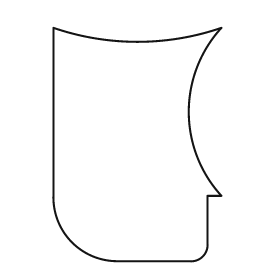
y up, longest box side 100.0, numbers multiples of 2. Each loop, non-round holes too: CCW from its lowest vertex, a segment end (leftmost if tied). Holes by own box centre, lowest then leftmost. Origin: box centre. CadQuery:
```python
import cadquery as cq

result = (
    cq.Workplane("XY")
    .moveTo(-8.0, -50.0)
    .lineTo(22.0, -50.0)
    .threePointArc((28.0, -48.0), (30.0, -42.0))
    .lineTo(30.0, -22.0)
    .lineTo(36.0, -22.0)
    .threePointArc((22.0, 14.0), (36.0, 50.0))
    .threePointArc((0.0, 44.0), (-36.0, 50.0))
    .lineTo(-36.0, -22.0)
    .threePointArc((-28.0, -42.0), (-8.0, -50.0))
    .close()
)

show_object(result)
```